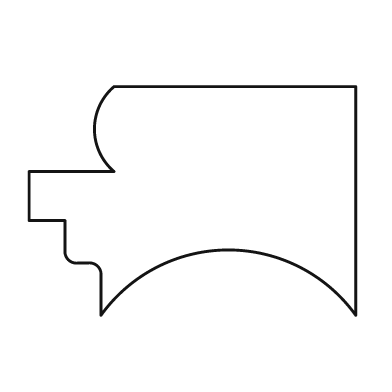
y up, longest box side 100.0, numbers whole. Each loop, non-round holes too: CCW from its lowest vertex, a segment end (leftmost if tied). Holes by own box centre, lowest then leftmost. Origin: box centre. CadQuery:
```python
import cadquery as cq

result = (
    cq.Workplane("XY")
    .moveTo(-28.0, -35.0)
    .threePointArc((11.0, -15.0), (50.0, -35.0))
    .lineTo(50.0, 35.0)
    .lineTo(-24.0, 35.0)
    .threePointArc((-30.0, 22.0), (-24.0, 9.0))
    .lineTo(-50.0, 9.0)
    .lineTo(-50.0, -6.0)
    .lineTo(-39.0, -6.0)
    .lineTo(-39.0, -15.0)
    .threePointArc((-38.0, -18.0), (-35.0, -19.0))
    .lineTo(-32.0, -19.0)
    .threePointArc((-29.0, -20.0), (-28.0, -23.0))
    .close()
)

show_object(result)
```